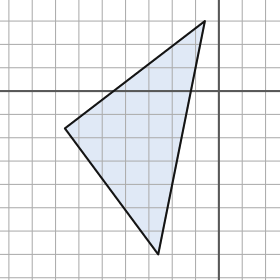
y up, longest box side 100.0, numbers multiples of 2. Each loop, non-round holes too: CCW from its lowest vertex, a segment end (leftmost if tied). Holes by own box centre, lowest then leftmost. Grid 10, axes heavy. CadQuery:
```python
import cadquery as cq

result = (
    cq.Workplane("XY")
    .moveTo(-26.0, -70.0)
    .lineTo(-6.0, 30.0)
    .lineTo(-66.0, -16.0)
    .close()
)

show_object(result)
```